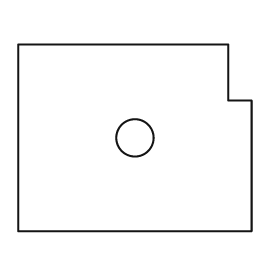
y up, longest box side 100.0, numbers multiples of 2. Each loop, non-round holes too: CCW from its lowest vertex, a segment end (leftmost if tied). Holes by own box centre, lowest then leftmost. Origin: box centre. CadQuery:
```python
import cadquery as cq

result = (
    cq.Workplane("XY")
    .moveTo(-50.0, -40.0)
    .lineTo(50.0, -40.0)
    .lineTo(50.0, 16.0)
    .lineTo(40.0, 16.0)
    .lineTo(40.0, 40.0)
    .lineTo(-50.0, 40.0)
    .close()
    .moveTo(0.0, 0.0)
    .circle(8.0)
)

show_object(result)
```